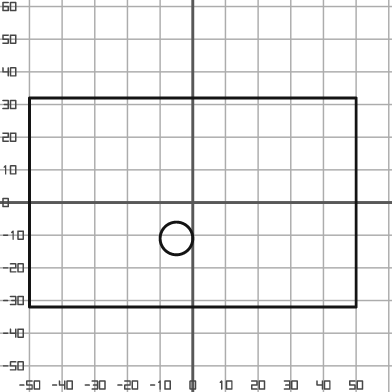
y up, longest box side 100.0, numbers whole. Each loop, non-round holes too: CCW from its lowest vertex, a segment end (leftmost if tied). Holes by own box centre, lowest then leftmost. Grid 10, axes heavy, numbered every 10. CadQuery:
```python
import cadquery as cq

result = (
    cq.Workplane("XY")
    .moveTo(-50.0, -32.0)
    .lineTo(50.0, -32.0)
    .lineTo(50.0, 32.0)
    .lineTo(-50.0, 32.0)
    .close()
    .moveTo(-5.0, -11.0)
    .circle(5.0)
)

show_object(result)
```